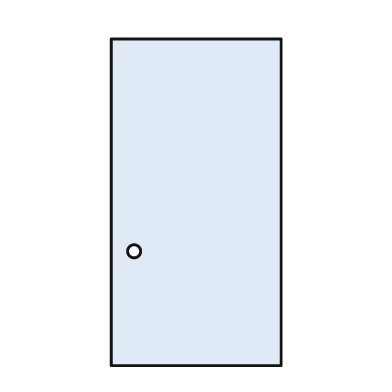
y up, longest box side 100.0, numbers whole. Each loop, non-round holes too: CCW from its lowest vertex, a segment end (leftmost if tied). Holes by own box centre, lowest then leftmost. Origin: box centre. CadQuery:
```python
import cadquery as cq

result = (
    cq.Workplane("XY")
    .moveTo(-26.0, -50.0)
    .lineTo(26.0, -50.0)
    .lineTo(26.0, 50.0)
    .lineTo(-26.0, 50.0)
    .close()
    .moveTo(-19.0, -15.0)
    .circle(2.0)
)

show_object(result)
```